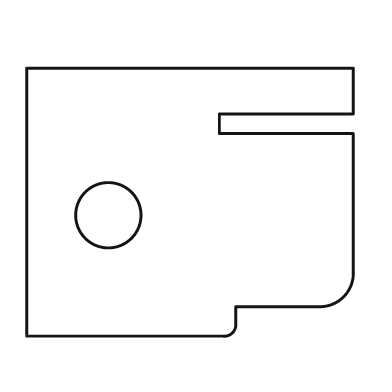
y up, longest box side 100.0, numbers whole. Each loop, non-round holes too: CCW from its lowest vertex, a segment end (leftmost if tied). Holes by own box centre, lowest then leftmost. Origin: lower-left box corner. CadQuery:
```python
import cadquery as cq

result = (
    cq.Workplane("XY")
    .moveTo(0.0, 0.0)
    .lineTo(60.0, 0.0)
    .threePointArc((63.0, 1.0), (64.0, 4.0))
    .lineTo(64.0, 9.0)
    .lineTo(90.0, 9.0)
    .threePointArc((97.0, 12.0), (100.0, 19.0))
    .lineTo(100.0, 62.0)
    .lineTo(59.0, 62.0)
    .lineTo(59.0, 68.0)
    .lineTo(100.0, 68.0)
    .lineTo(100.0, 82.0)
    .lineTo(0.0, 82.0)
    .close()
    .moveTo(25.0, 37.0)
    .circle(10.0)
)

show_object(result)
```